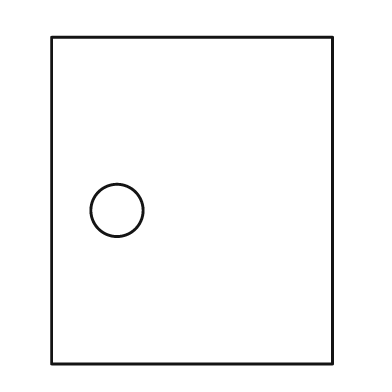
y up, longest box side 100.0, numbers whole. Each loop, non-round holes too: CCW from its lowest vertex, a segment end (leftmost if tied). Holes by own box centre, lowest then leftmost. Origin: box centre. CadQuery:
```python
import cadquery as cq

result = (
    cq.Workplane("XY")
    .moveTo(-43.0, -50.0)
    .lineTo(43.0, -50.0)
    .lineTo(43.0, 50.0)
    .lineTo(-43.0, 50.0)
    .close()
    .moveTo(-23.0, -3.0)
    .circle(8.0)
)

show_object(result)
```